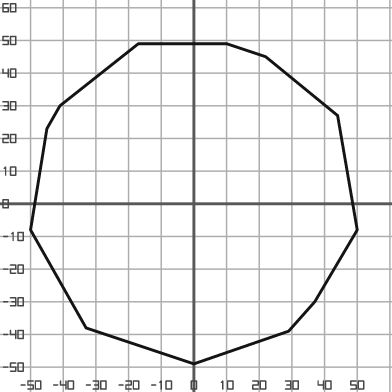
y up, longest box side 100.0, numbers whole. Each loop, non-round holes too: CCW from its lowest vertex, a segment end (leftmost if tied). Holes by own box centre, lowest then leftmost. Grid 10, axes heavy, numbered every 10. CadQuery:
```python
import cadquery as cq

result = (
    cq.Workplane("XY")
    .moveTo(0.0, -49.0)
    .lineTo(29.0, -39.0)
    .lineTo(37.0, -30.0)
    .lineTo(50.0, -8.0)
    .lineTo(44.0, 27.0)
    .lineTo(22.0, 45.0)
    .lineTo(10.0, 49.0)
    .lineTo(-17.0, 49.0)
    .lineTo(-41.0, 30.0)
    .lineTo(-45.0, 23.0)
    .lineTo(-50.0, -8.0)
    .lineTo(-33.0, -38.0)
    .close()
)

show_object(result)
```